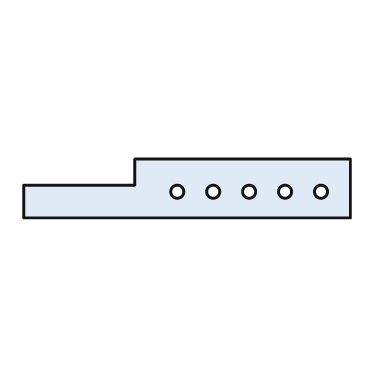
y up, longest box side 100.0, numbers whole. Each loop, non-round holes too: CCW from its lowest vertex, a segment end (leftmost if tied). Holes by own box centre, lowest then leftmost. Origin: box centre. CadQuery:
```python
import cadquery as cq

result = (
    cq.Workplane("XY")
    .moveTo(-50.0, -9.0)
    .lineTo(50.0, -9.0)
    .lineTo(50.0, 9.0)
    .lineTo(-16.0, 9.0)
    .lineTo(-16.0, 1.0)
    .lineTo(-50.0, 1.0)
    .close()
    .moveTo(-3.0, -1.0)
    .circle(2.0)
    .moveTo(8.0, -1.0)
    .circle(2.0)
    .moveTo(19.0, -1.0)
    .circle(2.0)
    .moveTo(30.0, -1.0)
    .circle(2.0)
    .moveTo(41.0, -1.0)
    .circle(2.0)
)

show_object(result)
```